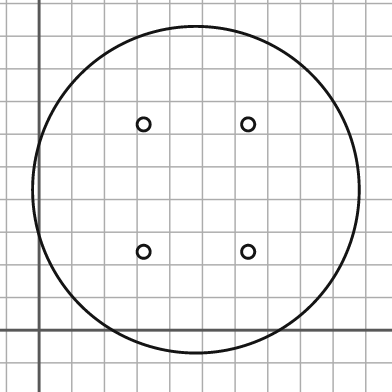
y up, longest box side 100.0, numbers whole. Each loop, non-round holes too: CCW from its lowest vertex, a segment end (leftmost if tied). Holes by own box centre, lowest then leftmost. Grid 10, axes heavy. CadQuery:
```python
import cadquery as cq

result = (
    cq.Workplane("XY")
    .moveTo(48.0, 43.0)
    .circle(50.0)
    .moveTo(32.0, 24.0)
    .circle(2.0)
    .moveTo(64.0, 24.0)
    .circle(2.0)
    .moveTo(32.0, 63.0)
    .circle(2.0)
    .moveTo(64.0, 63.0)
    .circle(2.0)
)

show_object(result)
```